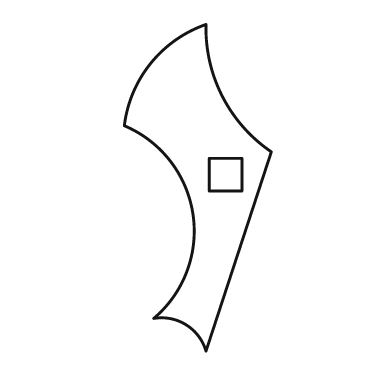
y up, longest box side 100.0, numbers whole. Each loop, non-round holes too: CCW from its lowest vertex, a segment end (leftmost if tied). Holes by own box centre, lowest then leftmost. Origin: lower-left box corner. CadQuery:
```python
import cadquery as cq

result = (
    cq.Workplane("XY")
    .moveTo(25.0, 0.0)
    .lineTo(45.0, 61.0)
    .threePointArc((30.0, 78.0), (25.0, 100.0))
    .threePointArc((8.0, 88.0), (0.0, 69.0))
    .threePointArc((21.0, 42.0), (9.0, 10.0))
    .threePointArc((19.0, 8.0), (25.0, 0.0))
    .close()
    .moveTo(26.0, 49.0)
    .lineTo(36.0, 49.0)
    .lineTo(36.0, 59.0)
    .lineTo(26.0, 59.0)
    .close()
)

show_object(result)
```